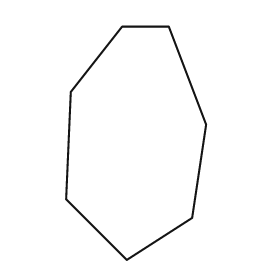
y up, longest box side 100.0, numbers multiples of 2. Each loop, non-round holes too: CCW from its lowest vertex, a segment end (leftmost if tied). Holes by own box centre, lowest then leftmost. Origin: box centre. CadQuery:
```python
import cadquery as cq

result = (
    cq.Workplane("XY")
    .moveTo(-4.0, -50.0)
    .lineTo(24.0, -32.0)
    .lineTo(30.0, 8.0)
    .lineTo(14.0, 50.0)
    .lineTo(-6.0, 50.0)
    .lineTo(-28.0, 22.0)
    .lineTo(-30.0, -24.0)
    .close()
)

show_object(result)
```